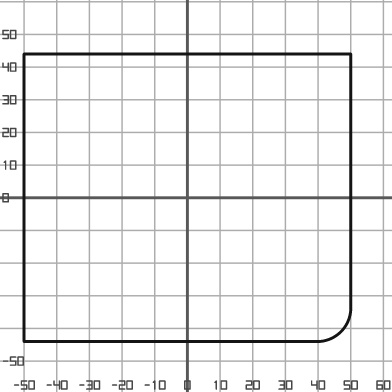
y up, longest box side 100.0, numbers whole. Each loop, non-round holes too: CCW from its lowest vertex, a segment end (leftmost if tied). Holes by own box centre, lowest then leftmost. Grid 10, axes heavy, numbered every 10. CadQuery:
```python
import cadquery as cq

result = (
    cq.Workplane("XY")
    .moveTo(-50.0, -44.0)
    .lineTo(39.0, -44.0)
    .threePointArc((47.0, -41.0), (50.0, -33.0))
    .lineTo(50.0, 44.0)
    .lineTo(-50.0, 44.0)
    .close()
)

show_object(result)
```